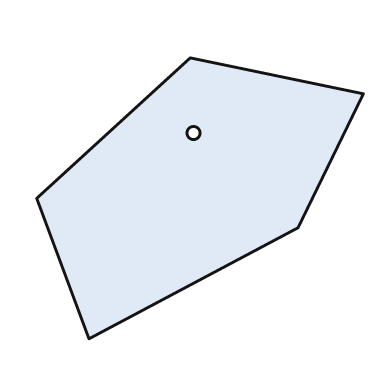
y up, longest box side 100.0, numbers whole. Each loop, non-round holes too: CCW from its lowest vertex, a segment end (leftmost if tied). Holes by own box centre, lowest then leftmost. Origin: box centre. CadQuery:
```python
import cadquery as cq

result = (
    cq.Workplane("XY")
    .moveTo(-34.0, -43.0)
    .lineTo(30.0, -9.0)
    .lineTo(50.0, 32.0)
    .lineTo(-3.0, 43.0)
    .lineTo(-50.0, 0.0)
    .close()
    .moveTo(-2.0, 20.0)
    .circle(2.0)
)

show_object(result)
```